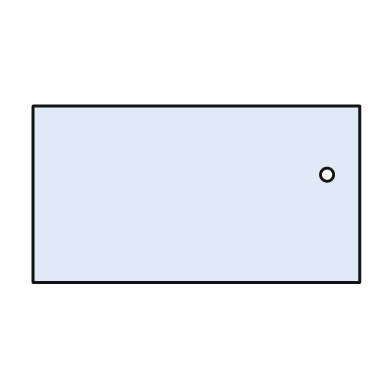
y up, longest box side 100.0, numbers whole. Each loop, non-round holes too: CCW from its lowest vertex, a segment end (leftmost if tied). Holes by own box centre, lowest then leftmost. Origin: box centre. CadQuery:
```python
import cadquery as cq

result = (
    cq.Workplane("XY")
    .moveTo(-50.0, -27.0)
    .lineTo(50.0, -27.0)
    .lineTo(50.0, 27.0)
    .lineTo(-50.0, 27.0)
    .close()
    .moveTo(40.0, 6.0)
    .circle(2.0)
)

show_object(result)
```